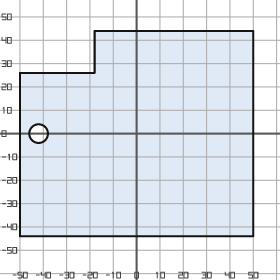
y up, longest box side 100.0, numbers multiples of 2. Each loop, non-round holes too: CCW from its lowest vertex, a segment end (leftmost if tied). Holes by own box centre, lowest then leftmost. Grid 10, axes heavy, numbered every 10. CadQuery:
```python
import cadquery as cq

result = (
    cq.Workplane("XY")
    .moveTo(-50.0, -44.0)
    .lineTo(50.0, -44.0)
    .lineTo(50.0, 44.0)
    .lineTo(-18.0, 44.0)
    .lineTo(-18.0, 26.0)
    .lineTo(-50.0, 26.0)
    .close()
    .moveTo(-42.0, 0.0)
    .circle(4.0)
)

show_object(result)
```